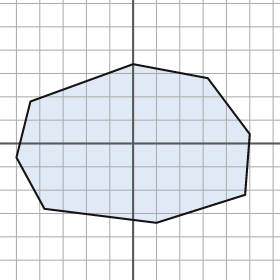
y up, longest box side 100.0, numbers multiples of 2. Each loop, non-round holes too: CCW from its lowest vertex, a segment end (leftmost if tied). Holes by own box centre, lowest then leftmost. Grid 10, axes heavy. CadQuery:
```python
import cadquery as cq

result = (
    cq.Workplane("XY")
    .moveTo(10.0, -34.0)
    .lineTo(48.0, -22.0)
    .lineTo(50.0, 4.0)
    .lineTo(32.0, 28.0)
    .lineTo(0.0, 34.0)
    .lineTo(-44.0, 18.0)
    .lineTo(-50.0, -6.0)
    .lineTo(-38.0, -28.0)
    .close()
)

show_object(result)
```